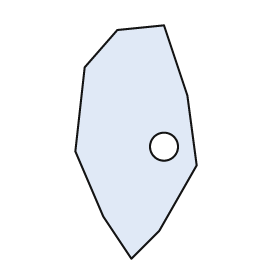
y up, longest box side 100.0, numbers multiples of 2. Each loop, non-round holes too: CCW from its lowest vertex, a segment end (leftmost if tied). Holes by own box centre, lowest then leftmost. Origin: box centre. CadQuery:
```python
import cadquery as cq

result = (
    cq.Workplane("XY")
    .moveTo(-2.0, -50.0)
    .lineTo(10.0, -38.0)
    .lineTo(26.0, -10.0)
    .lineTo(22.0, 20.0)
    .lineTo(12.0, 50.0)
    .lineTo(-8.0, 48.0)
    .lineTo(-22.0, 32.0)
    .lineTo(-26.0, -4.0)
    .lineTo(-14.0, -32.0)
    .close()
    .moveTo(12.0, -2.0)
    .circle(6.0)
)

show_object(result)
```